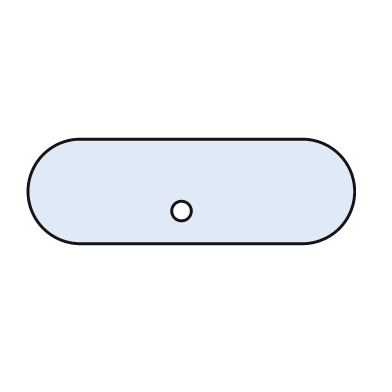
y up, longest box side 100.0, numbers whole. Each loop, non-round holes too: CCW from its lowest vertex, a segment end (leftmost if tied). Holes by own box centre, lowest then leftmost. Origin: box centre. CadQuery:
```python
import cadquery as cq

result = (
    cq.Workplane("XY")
    .moveTo(-34.0, -16.0)
    .lineTo(34.0, -16.0)
    .threePointArc((50.0, 0.0), (34.0, 16.0))
    .lineTo(-34.0, 16.0)
    .threePointArc((-50.0, 0.0), (-34.0, -16.0))
    .close()
    .moveTo(-3.0, -6.0)
    .circle(3.0)
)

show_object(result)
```